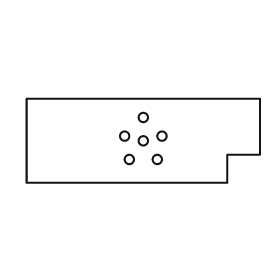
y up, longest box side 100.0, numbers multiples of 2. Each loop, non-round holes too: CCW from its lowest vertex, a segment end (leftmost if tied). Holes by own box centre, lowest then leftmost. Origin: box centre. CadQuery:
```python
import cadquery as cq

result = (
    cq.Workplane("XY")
    .moveTo(-50.0, -18.0)
    .lineTo(36.0, -18.0)
    .lineTo(36.0, -6.0)
    .lineTo(50.0, -6.0)
    .lineTo(50.0, 18.0)
    .lineTo(-50.0, 18.0)
    .close()
    .moveTo(-6.0, -8.0)
    .circle(2.0)
    .moveTo(6.0, -8.0)
    .circle(2.0)
    .moveTo(0.0, 0.0)
    .circle(2.0)
    .moveTo(-8.0, 2.0)
    .circle(2.0)
    .moveTo(8.0, 2.0)
    .circle(2.0)
    .moveTo(0.0, 10.0)
    .circle(2.0)
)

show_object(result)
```